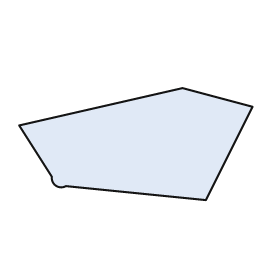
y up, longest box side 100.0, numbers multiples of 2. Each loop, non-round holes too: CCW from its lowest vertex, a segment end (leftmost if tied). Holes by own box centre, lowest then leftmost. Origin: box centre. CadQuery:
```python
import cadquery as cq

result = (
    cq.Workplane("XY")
    .moveTo(30.0, -24.0)
    .lineTo(50.0, 16.0)
    .lineTo(20.0, 24.0)
    .lineTo(-50.0, 8.0)
    .lineTo(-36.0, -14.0)
    .threePointArc((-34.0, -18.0), (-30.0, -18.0))
    .close()
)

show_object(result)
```